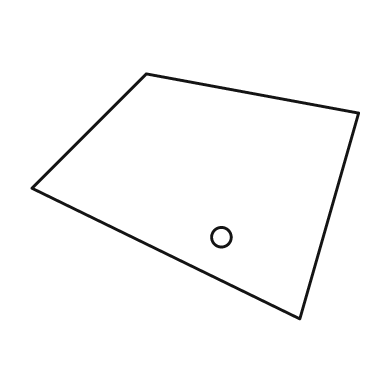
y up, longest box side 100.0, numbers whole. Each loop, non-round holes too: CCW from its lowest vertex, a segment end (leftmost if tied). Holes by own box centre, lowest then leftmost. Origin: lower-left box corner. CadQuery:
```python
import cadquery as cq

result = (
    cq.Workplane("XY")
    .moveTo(82.0, 0.0)
    .lineTo(100.0, 63.0)
    .lineTo(35.0, 75.0)
    .lineTo(0.0, 40.0)
    .close()
    .moveTo(58.0, 25.0)
    .circle(3.0)
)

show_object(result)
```